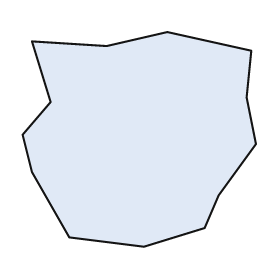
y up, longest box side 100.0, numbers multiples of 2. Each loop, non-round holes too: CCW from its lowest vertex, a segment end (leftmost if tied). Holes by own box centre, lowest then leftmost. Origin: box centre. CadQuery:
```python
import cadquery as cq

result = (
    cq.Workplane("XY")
    .moveTo(2.0, -46.0)
    .lineTo(28.0, -38.0)
    .lineTo(34.0, -24.0)
    .lineTo(50.0, -2.0)
    .lineTo(46.0, 18.0)
    .lineTo(48.0, 38.0)
    .lineTo(12.0, 46.0)
    .lineTo(-14.0, 40.0)
    .lineTo(-46.0, 42.0)
    .lineTo(-38.0, 16.0)
    .lineTo(-50.0, 2.0)
    .lineTo(-46.0, -14.0)
    .lineTo(-30.0, -42.0)
    .close()
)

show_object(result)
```